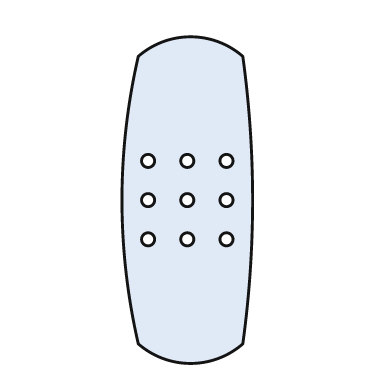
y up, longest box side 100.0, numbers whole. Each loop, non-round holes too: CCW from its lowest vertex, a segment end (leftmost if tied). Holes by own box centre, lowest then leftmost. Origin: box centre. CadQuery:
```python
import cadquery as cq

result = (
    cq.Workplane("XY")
    .moveTo(-15.0, -44.0)
    .threePointArc((1.0, -50.0), (17.0, -44.0))
    .threePointArc((20.0, 0.0), (17.0, 44.0))
    .threePointArc((1.0, 50.0), (-15.0, 44.0))
    .threePointArc((-20.0, 0.0), (-15.0, -44.0))
    .close()
    .moveTo(-12.0, -12.0)
    .circle(2.0)
    .moveTo(0.0, -12.0)
    .circle(2.0)
    .moveTo(12.0, -12.0)
    .circle(2.0)
    .moveTo(-12.0, 0.0)
    .circle(2.0)
    .moveTo(0.0, 0.0)
    .circle(2.0)
    .moveTo(12.0, 0.0)
    .circle(2.0)
    .moveTo(-12.0, 12.0)
    .circle(2.0)
    .moveTo(0.0, 12.0)
    .circle(2.0)
    .moveTo(12.0, 12.0)
    .circle(2.0)
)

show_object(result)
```